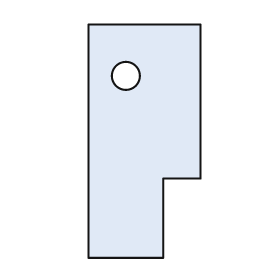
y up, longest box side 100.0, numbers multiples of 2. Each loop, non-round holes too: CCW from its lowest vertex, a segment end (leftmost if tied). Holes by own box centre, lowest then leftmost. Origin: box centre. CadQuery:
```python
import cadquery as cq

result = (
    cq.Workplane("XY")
    .moveTo(-24.0, -50.0)
    .lineTo(8.0, -50.0)
    .lineTo(8.0, -16.0)
    .lineTo(24.0, -16.0)
    .lineTo(24.0, 50.0)
    .lineTo(-24.0, 50.0)
    .close()
    .moveTo(-8.0, 28.0)
    .circle(6.0)
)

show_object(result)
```